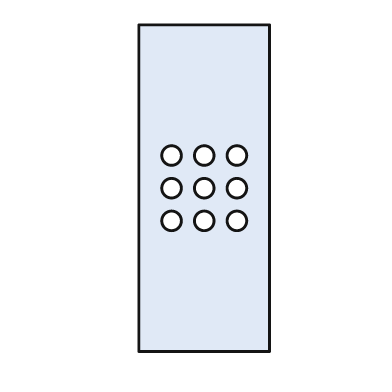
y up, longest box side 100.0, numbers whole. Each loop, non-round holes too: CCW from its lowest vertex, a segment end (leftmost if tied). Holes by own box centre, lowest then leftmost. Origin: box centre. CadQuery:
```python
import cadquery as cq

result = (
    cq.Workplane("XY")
    .moveTo(-20.0, -50.0)
    .lineTo(20.0, -50.0)
    .lineTo(20.0, 50.0)
    .lineTo(-20.0, 50.0)
    .close()
    .moveTo(-10.0, -10.0)
    .circle(3.0)
    .moveTo(0.0, -10.0)
    .circle(3.0)
    .moveTo(10.0, -10.0)
    .circle(3.0)
    .moveTo(-10.0, 0.0)
    .circle(3.0)
    .moveTo(0.0, 0.0)
    .circle(3.0)
    .moveTo(10.0, 0.0)
    .circle(3.0)
    .moveTo(-10.0, 10.0)
    .circle(3.0)
    .moveTo(0.0, 10.0)
    .circle(3.0)
    .moveTo(10.0, 10.0)
    .circle(3.0)
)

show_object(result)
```